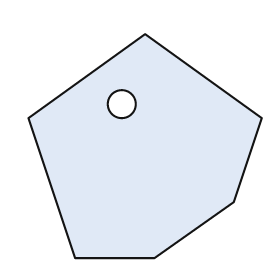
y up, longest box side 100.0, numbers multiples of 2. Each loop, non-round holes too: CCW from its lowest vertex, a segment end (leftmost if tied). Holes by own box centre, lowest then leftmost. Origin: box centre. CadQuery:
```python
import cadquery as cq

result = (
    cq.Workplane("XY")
    .moveTo(-30.0, -48.0)
    .lineTo(4.0, -48.0)
    .lineTo(38.0, -24.0)
    .lineTo(50.0, 12.0)
    .lineTo(0.0, 48.0)
    .lineTo(-50.0, 12.0)
    .close()
    .moveTo(-10.0, 18.0)
    .circle(6.0)
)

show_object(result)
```